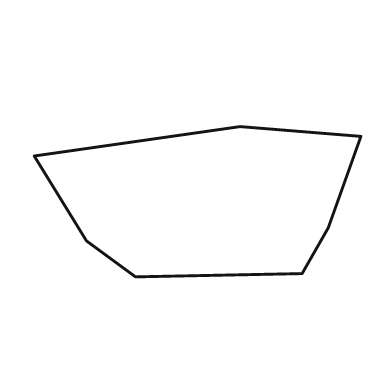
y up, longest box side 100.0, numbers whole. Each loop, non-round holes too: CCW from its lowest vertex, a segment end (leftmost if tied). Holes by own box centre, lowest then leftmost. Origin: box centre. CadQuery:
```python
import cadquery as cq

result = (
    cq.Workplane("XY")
    .moveTo(-19.0, -23.0)
    .lineTo(32.0, -22.0)
    .lineTo(40.0, -8.0)
    .lineTo(50.0, 20.0)
    .lineTo(13.0, 23.0)
    .lineTo(-50.0, 14.0)
    .lineTo(-34.0, -12.0)
    .close()
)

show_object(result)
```